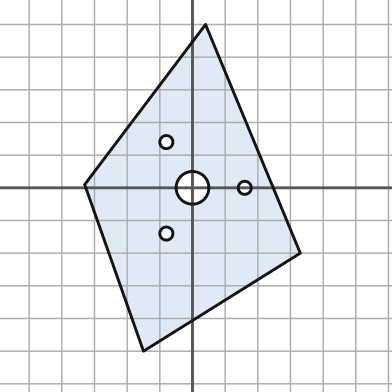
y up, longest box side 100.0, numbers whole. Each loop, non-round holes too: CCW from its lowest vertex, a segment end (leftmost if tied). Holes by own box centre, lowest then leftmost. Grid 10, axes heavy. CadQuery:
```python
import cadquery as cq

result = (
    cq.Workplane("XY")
    .moveTo(-15.0, -50.0)
    .lineTo(33.0, -20.0)
    .lineTo(4.0, 50.0)
    .lineTo(-33.0, 1.0)
    .close()
    .moveTo(-8.0, -14.0)
    .circle(2.0)
    .moveTo(0.0, 0.0)
    .circle(5.0)
    .moveTo(16.0, 0.0)
    .circle(2.0)
    .moveTo(-8.0, 14.0)
    .circle(2.0)
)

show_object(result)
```